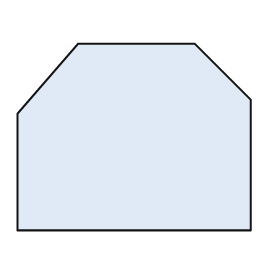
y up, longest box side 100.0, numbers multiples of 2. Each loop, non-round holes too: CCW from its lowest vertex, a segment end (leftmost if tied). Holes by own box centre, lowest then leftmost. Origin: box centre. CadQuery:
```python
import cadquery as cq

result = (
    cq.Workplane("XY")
    .moveTo(-50.0, -40.0)
    .lineTo(50.0, -40.0)
    .lineTo(50.0, 16.0)
    .lineTo(26.0, 40.0)
    .lineTo(-24.0, 40.0)
    .lineTo(-50.0, 10.0)
    .close()
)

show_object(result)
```